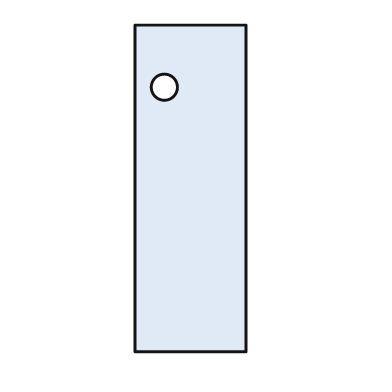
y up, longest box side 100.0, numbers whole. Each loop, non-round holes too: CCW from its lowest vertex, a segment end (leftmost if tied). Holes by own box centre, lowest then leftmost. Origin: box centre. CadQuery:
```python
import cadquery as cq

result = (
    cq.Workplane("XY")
    .moveTo(-17.0, -50.0)
    .lineTo(17.0, -50.0)
    .lineTo(17.0, 50.0)
    .lineTo(-17.0, 50.0)
    .close()
    .moveTo(-8.0, 31.0)
    .circle(4.0)
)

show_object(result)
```